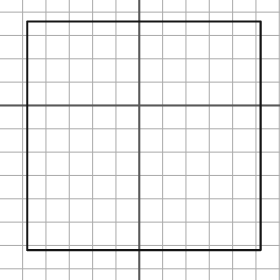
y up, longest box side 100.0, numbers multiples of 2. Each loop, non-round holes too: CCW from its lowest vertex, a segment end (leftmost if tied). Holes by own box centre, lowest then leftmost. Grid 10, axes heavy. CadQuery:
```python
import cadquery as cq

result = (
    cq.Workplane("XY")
    .moveTo(-48.0, -62.0)
    .lineTo(52.0, -62.0)
    .lineTo(52.0, 36.0)
    .lineTo(-48.0, 36.0)
    .close()
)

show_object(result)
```